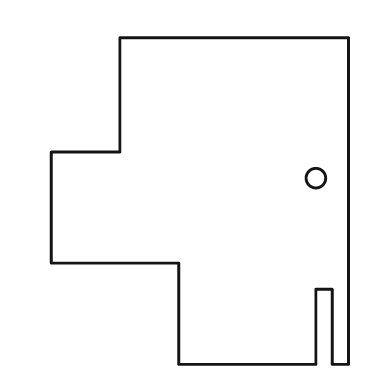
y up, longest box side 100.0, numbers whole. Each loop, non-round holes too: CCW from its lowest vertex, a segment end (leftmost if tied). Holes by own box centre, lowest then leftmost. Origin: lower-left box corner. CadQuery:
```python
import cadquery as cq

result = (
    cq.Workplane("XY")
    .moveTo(39.0, 0.0)
    .lineTo(81.0, 0.0)
    .lineTo(81.0, 23.0)
    .lineTo(86.0, 23.0)
    .lineTo(86.0, 0.0)
    .lineTo(91.0, 0.0)
    .lineTo(91.0, 100.0)
    .lineTo(21.0, 100.0)
    .lineTo(21.0, 65.0)
    .lineTo(0.0, 65.0)
    .lineTo(0.0, 31.0)
    .lineTo(39.0, 31.0)
    .close()
    .moveTo(81.0, 57.0)
    .circle(3.0)
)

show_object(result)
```